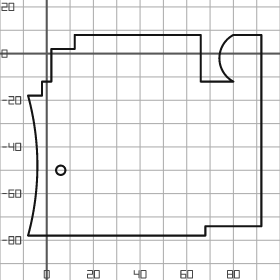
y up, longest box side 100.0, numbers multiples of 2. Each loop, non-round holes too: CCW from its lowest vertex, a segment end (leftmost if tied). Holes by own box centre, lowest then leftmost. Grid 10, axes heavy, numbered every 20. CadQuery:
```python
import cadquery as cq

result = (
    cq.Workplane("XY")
    .moveTo(-8.0, -78.0)
    .lineTo(68.0, -78.0)
    .lineTo(68.0, -74.0)
    .lineTo(92.0, -74.0)
    .lineTo(92.0, 8.0)
    .lineTo(80.0, 8.0)
    .threePointArc((74.0, -2.0), (80.0, -12.0))
    .lineTo(66.0, -12.0)
    .lineTo(66.0, 8.0)
    .lineTo(12.0, 8.0)
    .lineTo(12.0, 2.0)
    .lineTo(2.0, 2.0)
    .lineTo(2.0, -12.0)
    .lineTo(-2.0, -12.0)
    .lineTo(-2.0, -18.0)
    .lineTo(-8.0, -18.0)
    .threePointArc((-4.0, -48.0), (-8.0, -78.0))
    .close()
    .moveTo(6.0, -50.0)
    .circle(2.0)
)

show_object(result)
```